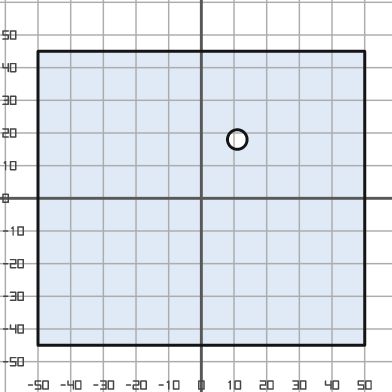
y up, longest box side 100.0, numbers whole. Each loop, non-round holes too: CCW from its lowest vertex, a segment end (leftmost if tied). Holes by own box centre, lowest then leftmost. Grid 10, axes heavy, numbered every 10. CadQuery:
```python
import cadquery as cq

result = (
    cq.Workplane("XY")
    .moveTo(-50.0, -45.0)
    .lineTo(50.0, -45.0)
    .lineTo(50.0, 45.0)
    .lineTo(-50.0, 45.0)
    .close()
    .moveTo(11.0, 18.0)
    .circle(3.0)
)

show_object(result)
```